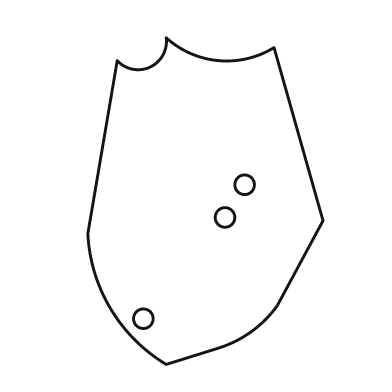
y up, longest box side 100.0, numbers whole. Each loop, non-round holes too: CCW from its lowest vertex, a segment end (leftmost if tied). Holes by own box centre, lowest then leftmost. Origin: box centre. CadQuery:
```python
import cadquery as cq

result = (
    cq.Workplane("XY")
    .moveTo(-12.0, -50.0)
    .lineTo(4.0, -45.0)
    .threePointArc((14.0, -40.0), (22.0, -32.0))
    .lineTo(36.0, -6.0)
    .lineTo(21.0, 47.0)
    .threePointArc((4.0, 43.0), (-12.0, 50.0))
    .threePointArc((-17.0, 41.0), (-27.0, 43.0))
    .lineTo(-36.0, -10.0)
    .threePointArc((-29.0, -33.0), (-12.0, -50.0))
    .close()
    .moveTo(-19.0, -36.0)
    .circle(3.0)
    .moveTo(6.0, -5.0)
    .circle(3.0)
    .moveTo(12.0, 5.0)
    .circle(3.0)
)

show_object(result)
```